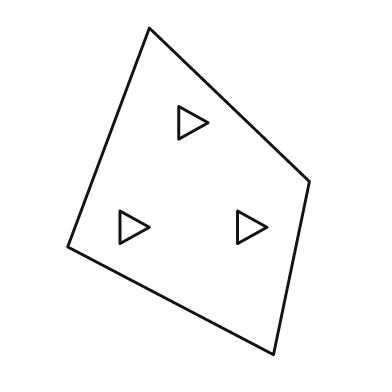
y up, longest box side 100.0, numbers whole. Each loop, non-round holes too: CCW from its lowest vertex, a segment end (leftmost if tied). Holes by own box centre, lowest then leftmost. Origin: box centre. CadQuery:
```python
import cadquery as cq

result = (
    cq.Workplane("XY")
    .moveTo(26.0, -50.0)
    .lineTo(37.0, 3.0)
    .lineTo(-12.0, 50.0)
    .lineTo(-37.0, -17.0)
    .close()
    .moveTo(-21.0, -16.0)
    .lineTo(-12.0, -11.0)
    .lineTo(-21.0, -6.0)
    .close()
    .moveTo(15.0, -16.0)
    .lineTo(24.0, -11.0)
    .lineTo(15.0, -6.0)
    .close()
    .moveTo(-3.0, 16.0)
    .lineTo(6.0, 21.0)
    .lineTo(-3.0, 26.0)
    .close()
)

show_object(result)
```